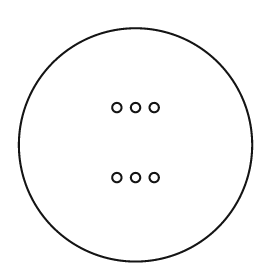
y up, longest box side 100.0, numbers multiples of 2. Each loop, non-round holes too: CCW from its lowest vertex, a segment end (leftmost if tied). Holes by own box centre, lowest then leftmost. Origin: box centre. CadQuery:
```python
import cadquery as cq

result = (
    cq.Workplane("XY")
    .moveTo(0.0, 0.0)
    .circle(50.0)
    .moveTo(-8.0, -14.0)
    .circle(2.0)
    .moveTo(0.0, -14.0)
    .circle(2.0)
    .moveTo(8.0, -14.0)
    .circle(2.0)
    .moveTo(-8.0, 16.0)
    .circle(2.0)
    .moveTo(0.0, 16.0)
    .circle(2.0)
    .moveTo(8.0, 16.0)
    .circle(2.0)
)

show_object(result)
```